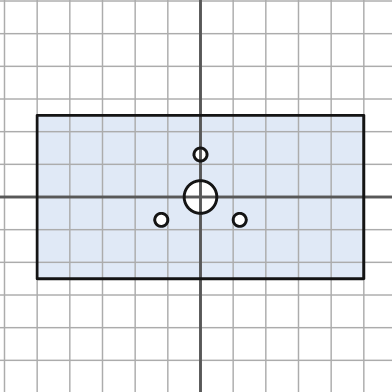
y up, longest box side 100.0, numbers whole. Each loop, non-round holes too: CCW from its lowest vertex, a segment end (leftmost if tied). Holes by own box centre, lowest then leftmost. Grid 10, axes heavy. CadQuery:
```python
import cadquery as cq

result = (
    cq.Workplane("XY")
    .moveTo(-50.0, -25.0)
    .lineTo(50.0, -25.0)
    .lineTo(50.0, 25.0)
    .lineTo(-50.0, 25.0)
    .close()
    .moveTo(-12.0, -7.0)
    .circle(2.0)
    .moveTo(12.0, -7.0)
    .circle(2.0)
    .moveTo(0.0, 0.0)
    .circle(5.0)
    .moveTo(0.0, 13.0)
    .circle(2.0)
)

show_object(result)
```